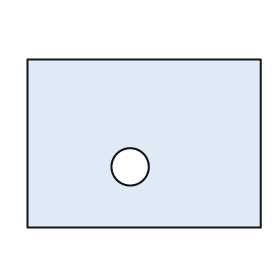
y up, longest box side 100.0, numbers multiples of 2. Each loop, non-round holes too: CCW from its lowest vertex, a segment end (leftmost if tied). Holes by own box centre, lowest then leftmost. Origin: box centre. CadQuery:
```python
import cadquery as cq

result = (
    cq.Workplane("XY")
    .moveTo(-50.0, -36.0)
    .lineTo(50.0, -36.0)
    .lineTo(50.0, 36.0)
    .lineTo(-50.0, 36.0)
    .close()
    .moveTo(-6.0, -10.0)
    .circle(8.0)
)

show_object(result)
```